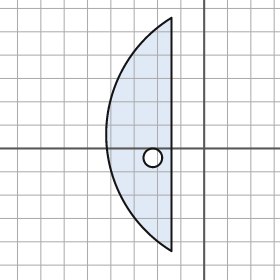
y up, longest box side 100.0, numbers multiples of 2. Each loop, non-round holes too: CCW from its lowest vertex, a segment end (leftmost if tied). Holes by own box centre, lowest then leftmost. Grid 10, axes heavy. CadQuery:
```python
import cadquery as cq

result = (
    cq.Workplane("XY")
    .moveTo(-14.0, -44.0)
    .lineTo(-14.0, 56.0)
    .threePointArc((-42.0, 6.0), (-14.0, -44.0))
    .close()
    .moveTo(-22.0, -4.0)
    .circle(4.0)
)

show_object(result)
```